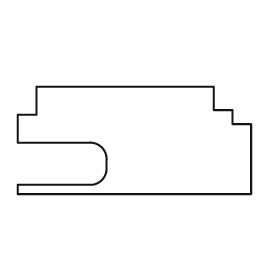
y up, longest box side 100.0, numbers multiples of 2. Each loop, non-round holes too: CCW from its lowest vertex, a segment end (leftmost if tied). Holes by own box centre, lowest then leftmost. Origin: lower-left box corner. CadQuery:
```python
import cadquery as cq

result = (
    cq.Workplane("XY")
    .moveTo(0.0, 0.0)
    .lineTo(100.0, 0.0)
    .lineTo(100.0, 30.0)
    .lineTo(92.0, 30.0)
    .lineTo(92.0, 36.0)
    .lineTo(84.0, 36.0)
    .lineTo(84.0, 46.0)
    .lineTo(8.0, 46.0)
    .lineTo(8.0, 34.0)
    .lineTo(0.0, 34.0)
    .lineTo(0.0, 22.0)
    .lineTo(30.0, 22.0)
    .threePointArc((36.0, 20.0), (38.0, 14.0))
    .lineTo(38.0, 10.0)
    .threePointArc((36.0, 6.0), (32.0, 4.0))
    .lineTo(0.0, 4.0)
    .close()
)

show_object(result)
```